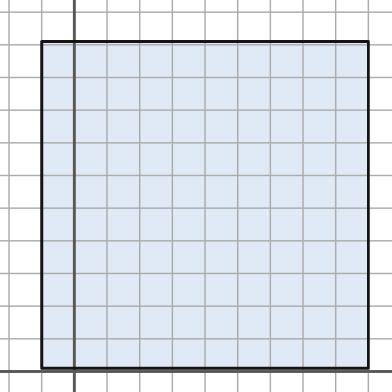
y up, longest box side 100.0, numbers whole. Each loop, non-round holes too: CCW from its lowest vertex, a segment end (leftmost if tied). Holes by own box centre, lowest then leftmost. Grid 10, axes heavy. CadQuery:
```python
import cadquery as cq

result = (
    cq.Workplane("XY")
    .moveTo(-10.0, 1.0)
    .lineTo(90.0, 1.0)
    .lineTo(90.0, 101.0)
    .lineTo(-10.0, 101.0)
    .close()
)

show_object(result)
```